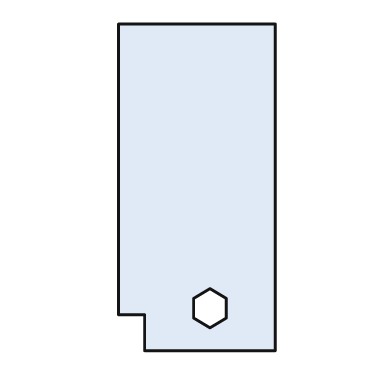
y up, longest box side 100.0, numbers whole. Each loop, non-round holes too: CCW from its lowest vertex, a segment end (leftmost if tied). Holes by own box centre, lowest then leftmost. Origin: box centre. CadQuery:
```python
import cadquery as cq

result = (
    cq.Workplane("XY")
    .moveTo(-16.0, -50.0)
    .lineTo(24.0, -50.0)
    .lineTo(24.0, 50.0)
    .lineTo(-24.0, 50.0)
    .lineTo(-24.0, -39.0)
    .lineTo(-16.0, -39.0)
    .close()
    .moveTo(4.0, -43.0)
    .lineTo(9.0, -40.0)
    .lineTo(9.0, -34.0)
    .lineTo(4.0, -31.0)
    .lineTo(-1.0, -34.0)
    .lineTo(-1.0, -40.0)
    .close()
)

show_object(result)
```